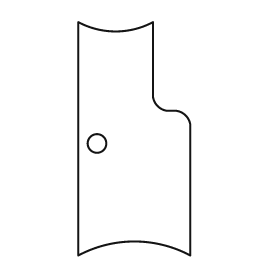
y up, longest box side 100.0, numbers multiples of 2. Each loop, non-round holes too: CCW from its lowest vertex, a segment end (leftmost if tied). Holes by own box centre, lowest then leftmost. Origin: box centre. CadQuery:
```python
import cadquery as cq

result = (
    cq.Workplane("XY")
    .moveTo(-24.0, -50.0)
    .threePointArc((0.0, -44.0), (24.0, -50.0))
    .lineTo(24.0, 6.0)
    .threePointArc((22.0, 10.0), (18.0, 12.0))
    .lineTo(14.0, 12.0)
    .threePointArc((10.0, 14.0), (8.0, 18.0))
    .lineTo(8.0, 50.0)
    .threePointArc((-8.0, 46.0), (-24.0, 50.0))
    .close()
    .moveTo(-16.0, -2.0)
    .circle(4.0)
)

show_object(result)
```